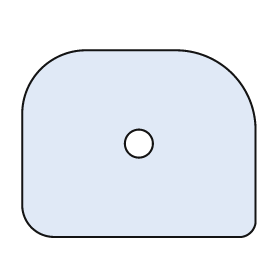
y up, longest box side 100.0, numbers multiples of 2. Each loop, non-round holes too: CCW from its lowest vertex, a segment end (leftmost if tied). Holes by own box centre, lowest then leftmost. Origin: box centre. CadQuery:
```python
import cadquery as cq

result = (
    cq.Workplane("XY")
    .moveTo(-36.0, -40.0)
    .lineTo(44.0, -40.0)
    .threePointArc((48.0, -38.0), (50.0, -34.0))
    .lineTo(50.0, 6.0)
    .threePointArc((40.0, 30.0), (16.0, 40.0))
    .lineTo(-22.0, 40.0)
    .threePointArc((-42.0, 32.0), (-50.0, 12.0))
    .lineTo(-50.0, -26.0)
    .threePointArc((-46.0, -36.0), (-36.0, -40.0))
    .close()
    .moveTo(0.0, 0.0)
    .circle(6.0)
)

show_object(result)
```